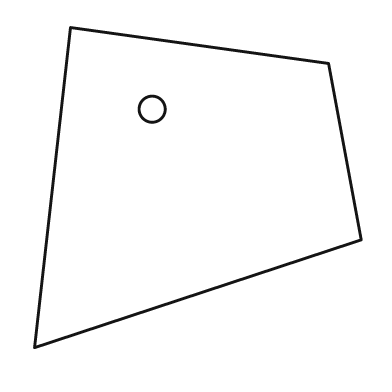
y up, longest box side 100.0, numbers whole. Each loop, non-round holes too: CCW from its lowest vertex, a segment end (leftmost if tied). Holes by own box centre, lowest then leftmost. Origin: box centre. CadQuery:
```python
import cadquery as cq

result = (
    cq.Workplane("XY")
    .moveTo(-50.0, -49.0)
    .lineTo(50.0, -16.0)
    .lineTo(40.0, 38.0)
    .lineTo(-39.0, 49.0)
    .close()
    .moveTo(-14.0, 24.0)
    .circle(4.0)
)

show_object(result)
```